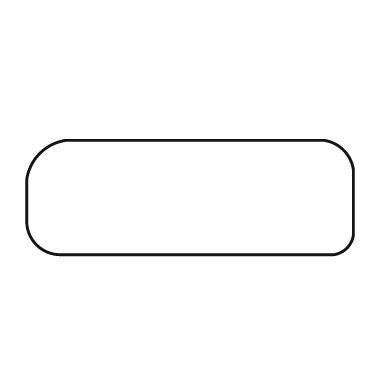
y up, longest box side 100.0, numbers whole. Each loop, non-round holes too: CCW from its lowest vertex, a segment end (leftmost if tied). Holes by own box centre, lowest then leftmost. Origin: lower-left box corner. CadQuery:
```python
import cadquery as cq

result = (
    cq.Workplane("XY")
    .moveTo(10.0, 0.0)
    .lineTo(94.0, 0.0)
    .threePointArc((98.0, 2.0), (100.0, 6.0))
    .lineTo(100.0, 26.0)
    .threePointArc((97.0, 32.0), (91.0, 35.0))
    .lineTo(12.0, 35.0)
    .threePointArc((4.0, 31.0), (0.0, 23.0))
    .lineTo(0.0, 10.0)
    .threePointArc((3.0, 3.0), (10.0, 0.0))
    .close()
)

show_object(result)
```